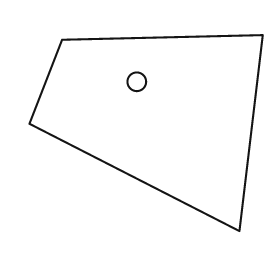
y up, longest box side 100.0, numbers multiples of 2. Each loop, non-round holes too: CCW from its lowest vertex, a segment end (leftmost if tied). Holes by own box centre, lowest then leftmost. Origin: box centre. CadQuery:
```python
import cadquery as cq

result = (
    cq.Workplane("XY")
    .moveTo(40.0, -42.0)
    .lineTo(50.0, 42.0)
    .lineTo(-36.0, 40.0)
    .lineTo(-50.0, 4.0)
    .close()
    .moveTo(-4.0, 22.0)
    .circle(4.0)
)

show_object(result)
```